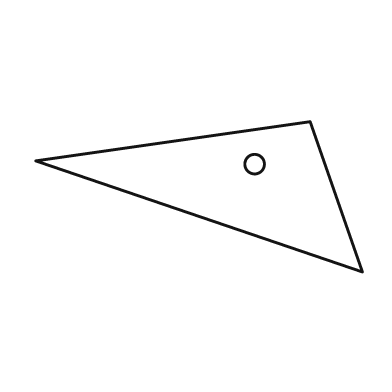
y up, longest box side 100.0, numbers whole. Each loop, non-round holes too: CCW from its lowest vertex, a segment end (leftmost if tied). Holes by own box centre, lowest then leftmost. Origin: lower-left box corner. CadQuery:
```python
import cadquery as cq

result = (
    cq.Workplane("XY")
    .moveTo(100.0, 0.0)
    .lineTo(84.0, 46.0)
    .lineTo(0.0, 34.0)
    .close()
    .moveTo(67.0, 33.0)
    .circle(3.0)
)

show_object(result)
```